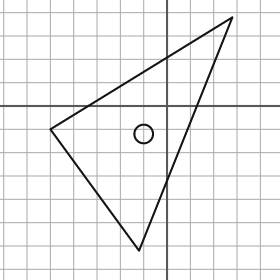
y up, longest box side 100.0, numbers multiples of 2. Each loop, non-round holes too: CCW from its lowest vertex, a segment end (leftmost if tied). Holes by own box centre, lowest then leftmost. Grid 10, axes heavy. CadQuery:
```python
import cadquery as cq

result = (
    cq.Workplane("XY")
    .moveTo(-12.0, -62.0)
    .lineTo(28.0, 38.0)
    .lineTo(-50.0, -10.0)
    .close()
    .moveTo(-10.0, -12.0)
    .circle(4.0)
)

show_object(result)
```